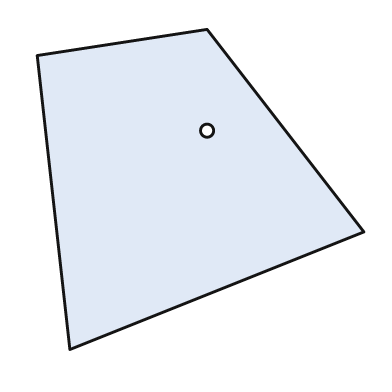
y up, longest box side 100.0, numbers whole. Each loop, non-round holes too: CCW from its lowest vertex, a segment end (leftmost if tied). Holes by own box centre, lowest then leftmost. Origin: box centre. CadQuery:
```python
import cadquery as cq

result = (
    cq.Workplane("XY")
    .moveTo(-40.0, -49.0)
    .lineTo(50.0, -13.0)
    .lineTo(2.0, 49.0)
    .lineTo(-50.0, 41.0)
    .close()
    .moveTo(2.0, 18.0)
    .circle(2.0)
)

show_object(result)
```